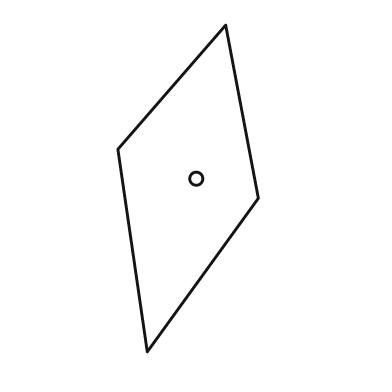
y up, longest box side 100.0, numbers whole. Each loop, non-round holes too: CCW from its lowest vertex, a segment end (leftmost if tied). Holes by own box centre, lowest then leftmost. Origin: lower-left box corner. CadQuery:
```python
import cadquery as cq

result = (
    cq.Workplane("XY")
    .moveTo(9.0, 0.0)
    .lineTo(43.0, 47.0)
    .lineTo(33.0, 100.0)
    .lineTo(0.0, 62.0)
    .close()
    .moveTo(24.0, 53.0)
    .circle(2.0)
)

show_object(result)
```